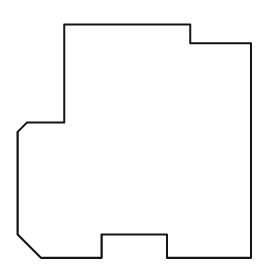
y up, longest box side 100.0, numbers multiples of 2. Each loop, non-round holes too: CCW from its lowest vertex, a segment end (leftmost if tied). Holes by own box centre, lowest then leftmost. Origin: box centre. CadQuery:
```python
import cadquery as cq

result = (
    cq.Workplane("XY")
    .moveTo(-40.0, -50.0)
    .lineTo(-14.0, -50.0)
    .lineTo(-14.0, -40.0)
    .lineTo(14.0, -40.0)
    .lineTo(14.0, -50.0)
    .lineTo(50.0, -50.0)
    .lineTo(50.0, 42.0)
    .lineTo(24.0, 42.0)
    .lineTo(24.0, 50.0)
    .lineTo(-30.0, 50.0)
    .lineTo(-30.0, 8.0)
    .lineTo(-46.0, 8.0)
    .lineTo(-50.0, 4.0)
    .lineTo(-50.0, -40.0)
    .close()
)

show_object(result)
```